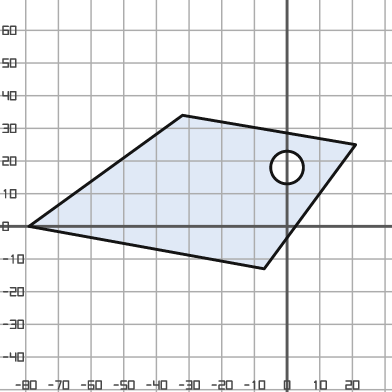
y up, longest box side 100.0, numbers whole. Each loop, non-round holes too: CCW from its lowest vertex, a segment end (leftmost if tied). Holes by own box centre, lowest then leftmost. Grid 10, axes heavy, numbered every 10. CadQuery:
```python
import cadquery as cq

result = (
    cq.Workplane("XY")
    .moveTo(-7.0, -13.0)
    .lineTo(21.0, 25.0)
    .lineTo(-32.0, 34.0)
    .lineTo(-79.0, 0.0)
    .close()
    .moveTo(0.0, 18.0)
    .circle(5.0)
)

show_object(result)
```